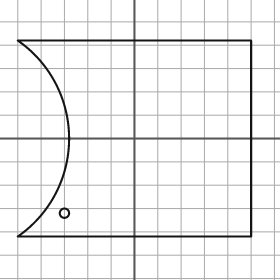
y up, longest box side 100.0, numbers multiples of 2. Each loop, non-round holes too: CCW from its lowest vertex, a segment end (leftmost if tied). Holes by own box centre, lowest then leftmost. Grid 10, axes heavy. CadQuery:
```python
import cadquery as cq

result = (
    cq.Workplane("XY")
    .moveTo(-50.0, -42.0)
    .lineTo(50.0, -42.0)
    .lineTo(50.0, 42.0)
    .lineTo(-50.0, 42.0)
    .threePointArc((-28.0, 0.0), (-50.0, -42.0))
    .close()
    .moveTo(-30.0, -32.0)
    .circle(2.0)
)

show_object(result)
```